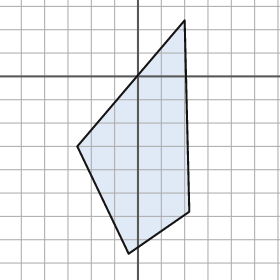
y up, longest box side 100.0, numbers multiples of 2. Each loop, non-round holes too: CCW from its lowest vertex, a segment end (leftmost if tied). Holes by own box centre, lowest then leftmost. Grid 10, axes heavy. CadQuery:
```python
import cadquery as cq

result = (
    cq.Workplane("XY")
    .moveTo(-4.0, -76.0)
    .lineTo(22.0, -58.0)
    .lineTo(20.0, 24.0)
    .lineTo(-26.0, -30.0)
    .close()
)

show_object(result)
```